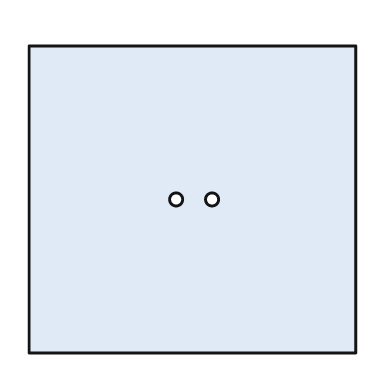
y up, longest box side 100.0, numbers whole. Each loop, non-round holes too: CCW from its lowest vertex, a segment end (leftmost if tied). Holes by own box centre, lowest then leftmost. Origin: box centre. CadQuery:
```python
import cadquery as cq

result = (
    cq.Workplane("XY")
    .moveTo(-50.0, -47.0)
    .lineTo(50.0, -47.0)
    .lineTo(50.0, 47.0)
    .lineTo(-50.0, 47.0)
    .close()
    .moveTo(-5.0, 0.0)
    .circle(2.0)
    .moveTo(6.0, 0.0)
    .circle(2.0)
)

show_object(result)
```